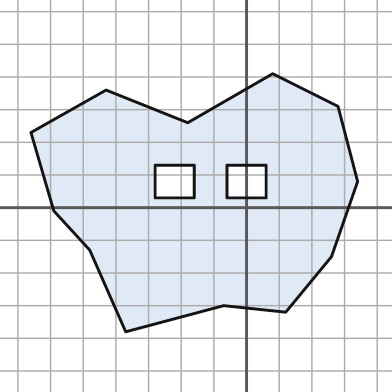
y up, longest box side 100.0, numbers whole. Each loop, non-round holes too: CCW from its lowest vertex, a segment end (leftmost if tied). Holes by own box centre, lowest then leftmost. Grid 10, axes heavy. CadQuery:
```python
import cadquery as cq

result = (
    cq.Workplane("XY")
    .moveTo(-37.0, -38.0)
    .lineTo(-7.0, -30.0)
    .lineTo(12.0, -32.0)
    .lineTo(26.0, -15.0)
    .lineTo(34.0, 8.0)
    .lineTo(28.0, 31.0)
    .lineTo(8.0, 41.0)
    .lineTo(-18.0, 26.0)
    .lineTo(-43.0, 36.0)
    .lineTo(-66.0, 23.0)
    .lineTo(-59.0, -1.0)
    .lineTo(-48.0, -13.0)
    .close()
    .moveTo(-28.0, 3.0)
    .lineTo(-16.0, 3.0)
    .lineTo(-16.0, 13.0)
    .lineTo(-28.0, 13.0)
    .close()
    .moveTo(-6.0, 3.0)
    .lineTo(6.0, 3.0)
    .lineTo(6.0, 13.0)
    .lineTo(-6.0, 13.0)
    .close()
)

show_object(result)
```